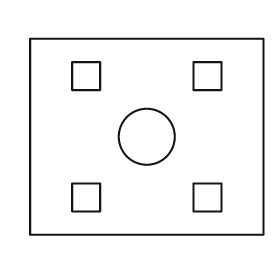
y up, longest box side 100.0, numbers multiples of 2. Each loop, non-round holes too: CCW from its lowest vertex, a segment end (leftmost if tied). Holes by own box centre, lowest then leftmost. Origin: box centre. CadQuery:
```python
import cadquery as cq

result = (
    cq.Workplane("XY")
    .moveTo(-50.0, -42.0)
    .lineTo(50.0, -42.0)
    .lineTo(50.0, 42.0)
    .lineTo(-50.0, 42.0)
    .close()
    .moveTo(-32.0, -32.0)
    .lineTo(-20.0, -32.0)
    .lineTo(-20.0, -20.0)
    .lineTo(-32.0, -20.0)
    .close()
    .moveTo(20.0, -32.0)
    .lineTo(32.0, -32.0)
    .lineTo(32.0, -20.0)
    .lineTo(20.0, -20.0)
    .close()
    .moveTo(0.0, 0.0)
    .circle(12.0)
    .moveTo(-32.0, 20.0)
    .lineTo(-20.0, 20.0)
    .lineTo(-20.0, 32.0)
    .lineTo(-32.0, 32.0)
    .close()
    .moveTo(20.0, 20.0)
    .lineTo(32.0, 20.0)
    .lineTo(32.0, 32.0)
    .lineTo(20.0, 32.0)
    .close()
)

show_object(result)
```